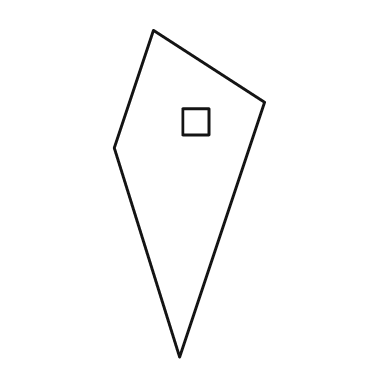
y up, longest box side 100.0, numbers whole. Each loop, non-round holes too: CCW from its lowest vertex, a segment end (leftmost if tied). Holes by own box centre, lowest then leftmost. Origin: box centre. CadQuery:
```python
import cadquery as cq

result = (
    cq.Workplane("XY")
    .moveTo(-3.0, -50.0)
    .lineTo(23.0, 28.0)
    .lineTo(-11.0, 50.0)
    .lineTo(-23.0, 14.0)
    .close()
    .moveTo(-2.0, 18.0)
    .lineTo(6.0, 18.0)
    .lineTo(6.0, 26.0)
    .lineTo(-2.0, 26.0)
    .close()
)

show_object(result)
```